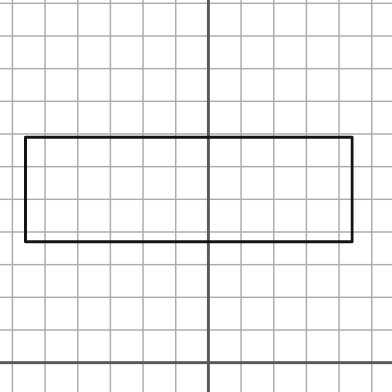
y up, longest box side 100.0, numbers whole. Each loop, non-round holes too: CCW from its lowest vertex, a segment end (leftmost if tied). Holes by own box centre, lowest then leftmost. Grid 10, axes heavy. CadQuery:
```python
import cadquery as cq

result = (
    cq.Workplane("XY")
    .moveTo(-56.0, 37.0)
    .lineTo(44.0, 37.0)
    .lineTo(44.0, 69.0)
    .lineTo(-56.0, 69.0)
    .close()
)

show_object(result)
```